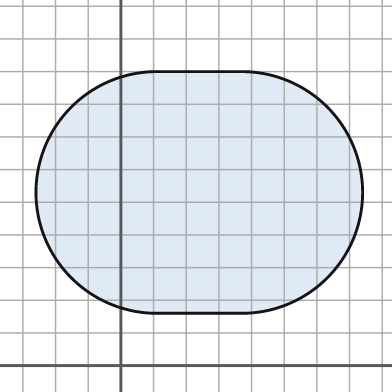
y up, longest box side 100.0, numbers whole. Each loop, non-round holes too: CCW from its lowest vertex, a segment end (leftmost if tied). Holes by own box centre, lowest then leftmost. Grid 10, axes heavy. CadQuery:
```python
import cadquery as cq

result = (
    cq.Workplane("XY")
    .moveTo(11.0, 16.0)
    .lineTo(37.0, 16.0)
    .threePointArc((74.0, 53.0), (37.0, 90.0))
    .lineTo(11.0, 90.0)
    .threePointArc((-26.0, 53.0), (11.0, 16.0))
    .close()
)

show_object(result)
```